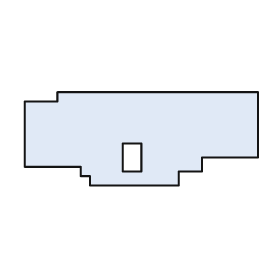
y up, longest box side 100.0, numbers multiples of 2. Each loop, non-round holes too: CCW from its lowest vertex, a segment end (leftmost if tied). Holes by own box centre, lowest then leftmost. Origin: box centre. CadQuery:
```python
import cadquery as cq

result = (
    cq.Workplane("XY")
    .moveTo(-22.0, -20.0)
    .lineTo(16.0, -20.0)
    .lineTo(16.0, -14.0)
    .lineTo(26.0, -14.0)
    .lineTo(26.0, -8.0)
    .lineTo(50.0, -8.0)
    .lineTo(50.0, 20.0)
    .lineTo(-36.0, 20.0)
    .lineTo(-36.0, 16.0)
    .lineTo(-50.0, 16.0)
    .lineTo(-50.0, -12.0)
    .lineTo(-26.0, -12.0)
    .lineTo(-26.0, -16.0)
    .lineTo(-22.0, -16.0)
    .close()
    .moveTo(-8.0, -14.0)
    .lineTo(0.0, -14.0)
    .lineTo(0.0, -2.0)
    .lineTo(-8.0, -2.0)
    .close()
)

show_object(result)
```